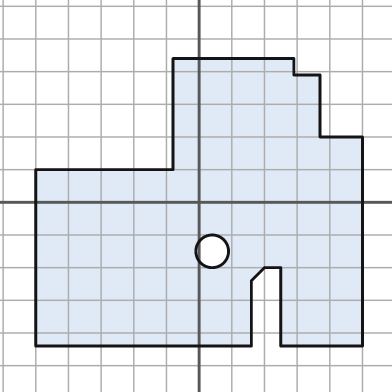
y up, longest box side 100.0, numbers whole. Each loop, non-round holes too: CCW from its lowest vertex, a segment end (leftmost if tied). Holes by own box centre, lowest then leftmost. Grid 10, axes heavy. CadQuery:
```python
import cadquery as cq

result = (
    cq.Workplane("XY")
    .moveTo(-50.0, -44.0)
    .lineTo(16.0, -44.0)
    .lineTo(16.0, -24.0)
    .lineTo(20.0, -20.0)
    .lineTo(25.0, -20.0)
    .lineTo(25.0, -44.0)
    .lineTo(50.0, -44.0)
    .lineTo(50.0, 20.0)
    .lineTo(37.0, 20.0)
    .lineTo(37.0, 39.0)
    .lineTo(29.0, 39.0)
    .lineTo(29.0, 44.0)
    .lineTo(-8.0, 44.0)
    .lineTo(-8.0, 10.0)
    .lineTo(-50.0, 10.0)
    .close()
    .moveTo(4.0, -15.0)
    .circle(5.0)
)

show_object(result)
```